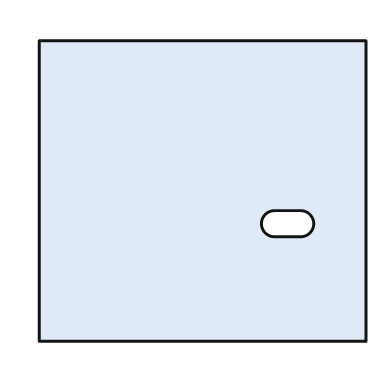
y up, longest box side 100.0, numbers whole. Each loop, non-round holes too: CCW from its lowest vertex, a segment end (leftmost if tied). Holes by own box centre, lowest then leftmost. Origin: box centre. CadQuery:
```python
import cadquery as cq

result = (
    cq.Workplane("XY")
    .moveTo(-50.0, -46.0)
    .lineTo(50.0, -46.0)
    .lineTo(50.0, 46.0)
    .lineTo(-50.0, 46.0)
    .close()
    .moveTo(22.0, -14.0)
    .lineTo(30.0, -14.0)
    .threePointArc((34.0, -10.0), (30.0, -6.0))
    .lineTo(22.0, -6.0)
    .threePointArc((18.0, -10.0), (22.0, -14.0))
    .close()
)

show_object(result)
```